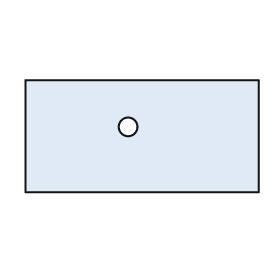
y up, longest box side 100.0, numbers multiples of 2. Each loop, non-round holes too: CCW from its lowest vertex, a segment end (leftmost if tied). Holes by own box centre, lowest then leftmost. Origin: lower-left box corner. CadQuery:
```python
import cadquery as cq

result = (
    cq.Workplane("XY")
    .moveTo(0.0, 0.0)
    .lineTo(100.0, 0.0)
    .lineTo(100.0, 48.0)
    .lineTo(0.0, 48.0)
    .close()
    .moveTo(44.0, 28.0)
    .circle(4.0)
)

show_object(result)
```